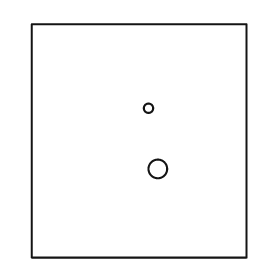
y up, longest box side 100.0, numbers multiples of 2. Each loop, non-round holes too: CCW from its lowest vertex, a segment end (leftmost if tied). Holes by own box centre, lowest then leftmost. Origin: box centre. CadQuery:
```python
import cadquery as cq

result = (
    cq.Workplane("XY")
    .moveTo(-46.0, -50.0)
    .lineTo(46.0, -50.0)
    .lineTo(46.0, 50.0)
    .lineTo(-46.0, 50.0)
    .close()
    .moveTo(8.0, -12.0)
    .circle(4.0)
    .moveTo(4.0, 14.0)
    .circle(2.0)
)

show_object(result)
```